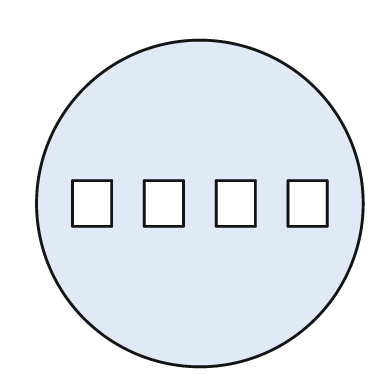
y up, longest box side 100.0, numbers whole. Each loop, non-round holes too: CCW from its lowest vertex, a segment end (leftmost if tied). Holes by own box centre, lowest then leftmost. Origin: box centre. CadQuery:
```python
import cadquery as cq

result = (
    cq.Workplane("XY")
    .moveTo(0.0, 0.0)
    .circle(50.0)
    .moveTo(-39.0, -7.0)
    .lineTo(-27.0, -7.0)
    .lineTo(-27.0, 7.0)
    .lineTo(-39.0, 7.0)
    .close()
    .moveTo(-17.0, -7.0)
    .lineTo(-5.0, -7.0)
    .lineTo(-5.0, 7.0)
    .lineTo(-17.0, 7.0)
    .close()
    .moveTo(5.0, -7.0)
    .lineTo(17.0, -7.0)
    .lineTo(17.0, 7.0)
    .lineTo(5.0, 7.0)
    .close()
    .moveTo(27.0, -7.0)
    .lineTo(39.0, -7.0)
    .lineTo(39.0, 7.0)
    .lineTo(27.0, 7.0)
    .close()
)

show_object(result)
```